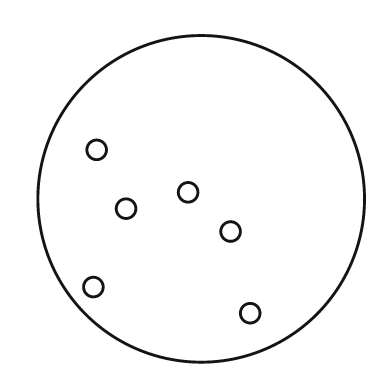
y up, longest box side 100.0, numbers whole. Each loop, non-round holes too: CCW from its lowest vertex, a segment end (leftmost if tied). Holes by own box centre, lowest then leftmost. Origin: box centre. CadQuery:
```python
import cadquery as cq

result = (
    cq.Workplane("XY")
    .moveTo(0.0, 0.0)
    .circle(50.0)
    .moveTo(15.0, -35.0)
    .circle(3.0)
    .moveTo(-33.0, -27.0)
    .circle(3.0)
    .moveTo(9.0, -10.0)
    .circle(3.0)
    .moveTo(-23.0, -3.0)
    .circle(3.0)
    .moveTo(-4.0, 2.0)
    .circle(3.0)
    .moveTo(-32.0, 15.0)
    .circle(3.0)
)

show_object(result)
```